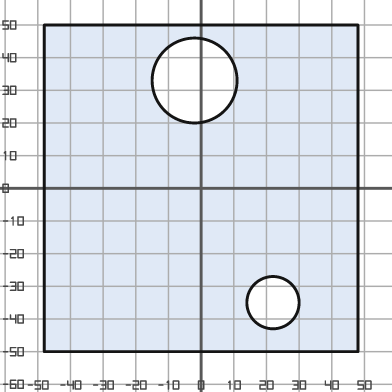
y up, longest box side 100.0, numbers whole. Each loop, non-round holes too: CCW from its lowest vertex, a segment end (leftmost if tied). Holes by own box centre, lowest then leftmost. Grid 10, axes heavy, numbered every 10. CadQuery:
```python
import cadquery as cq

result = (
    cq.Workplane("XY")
    .moveTo(-48.0, -50.0)
    .lineTo(48.0, -50.0)
    .lineTo(48.0, 50.0)
    .lineTo(-48.0, 50.0)
    .close()
    .moveTo(22.0, -35.0)
    .circle(8.0)
    .moveTo(-2.0, 33.0)
    .circle(13.0)
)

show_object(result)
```